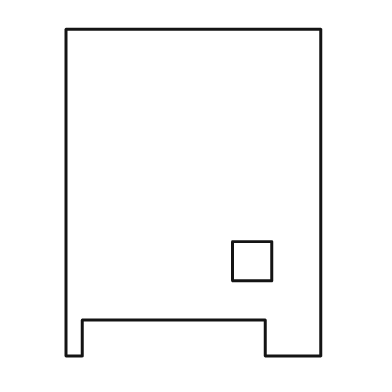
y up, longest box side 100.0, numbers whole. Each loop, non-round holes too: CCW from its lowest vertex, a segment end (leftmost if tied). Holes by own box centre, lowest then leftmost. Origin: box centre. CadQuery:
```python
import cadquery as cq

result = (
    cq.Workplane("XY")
    .moveTo(-39.0, -50.0)
    .lineTo(-34.0, -50.0)
    .lineTo(-34.0, -39.0)
    .lineTo(22.0, -39.0)
    .lineTo(22.0, -50.0)
    .lineTo(39.0, -50.0)
    .lineTo(39.0, 50.0)
    .lineTo(-39.0, 50.0)
    .close()
    .moveTo(12.0, -27.0)
    .lineTo(24.0, -27.0)
    .lineTo(24.0, -15.0)
    .lineTo(12.0, -15.0)
    .close()
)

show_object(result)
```